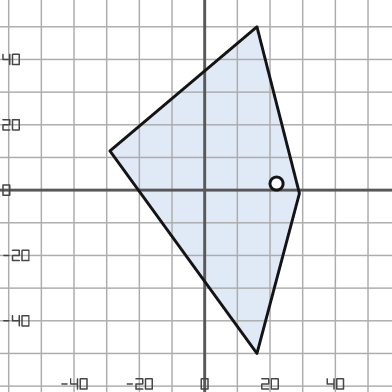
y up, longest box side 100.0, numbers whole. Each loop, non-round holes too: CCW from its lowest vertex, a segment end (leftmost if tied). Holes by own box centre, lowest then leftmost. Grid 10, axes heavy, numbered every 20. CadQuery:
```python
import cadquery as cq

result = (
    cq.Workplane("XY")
    .moveTo(16.0, -50.0)
    .lineTo(29.0, -1.0)
    .lineTo(16.0, 50.0)
    .lineTo(-29.0, 12.0)
    .close()
    .moveTo(22.0, 2.0)
    .circle(2.0)
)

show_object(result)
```